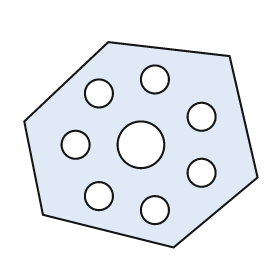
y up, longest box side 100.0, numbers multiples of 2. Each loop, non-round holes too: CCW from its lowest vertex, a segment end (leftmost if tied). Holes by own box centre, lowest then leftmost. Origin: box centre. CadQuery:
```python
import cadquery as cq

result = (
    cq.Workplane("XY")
    .moveTo(14.0, -44.0)
    .lineTo(50.0, -14.0)
    .lineTo(38.0, 38.0)
    .lineTo(-14.0, 44.0)
    .lineTo(-50.0, 10.0)
    .lineTo(-42.0, -30.0)
    .close()
    .moveTo(6.0, -28.0)
    .circle(6.0)
    .moveTo(-18.0, -22.0)
    .circle(6.0)
    .moveTo(26.0, -12.0)
    .circle(6.0)
    .moveTo(-28.0, 0.0)
    .circle(6.0)
    .moveTo(0.0, 0.0)
    .circle(10.0)
    .moveTo(26.0, 12.0)
    .circle(6.0)
    .moveTo(-18.0, 22.0)
    .circle(6.0)
    .moveTo(6.0, 28.0)
    .circle(6.0)
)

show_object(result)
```